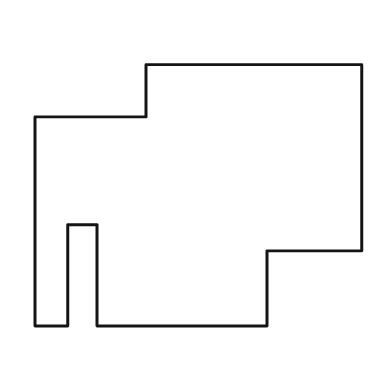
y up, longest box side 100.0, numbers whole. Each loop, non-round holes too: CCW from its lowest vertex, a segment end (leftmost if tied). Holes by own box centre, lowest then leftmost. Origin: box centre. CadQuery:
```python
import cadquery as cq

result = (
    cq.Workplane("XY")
    .moveTo(-50.0, -40.0)
    .lineTo(-40.0, -40.0)
    .lineTo(-40.0, -9.0)
    .lineTo(-31.0, -9.0)
    .lineTo(-31.0, -40.0)
    .lineTo(21.0, -40.0)
    .lineTo(21.0, -17.0)
    .lineTo(50.0, -17.0)
    .lineTo(50.0, 40.0)
    .lineTo(-16.0, 40.0)
    .lineTo(-16.0, 24.0)
    .lineTo(-50.0, 24.0)
    .close()
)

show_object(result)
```